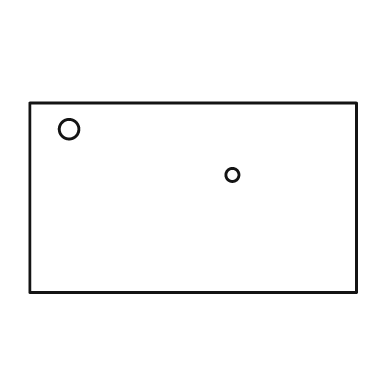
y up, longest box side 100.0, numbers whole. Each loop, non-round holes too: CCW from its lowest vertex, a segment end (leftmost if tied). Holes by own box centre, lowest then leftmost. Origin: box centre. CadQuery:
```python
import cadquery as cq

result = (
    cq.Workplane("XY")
    .moveTo(-50.0, -29.0)
    .lineTo(50.0, -29.0)
    .lineTo(50.0, 29.0)
    .lineTo(-50.0, 29.0)
    .close()
    .moveTo(12.0, 7.0)
    .circle(2.0)
    .moveTo(-38.0, 21.0)
    .circle(3.0)
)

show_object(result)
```